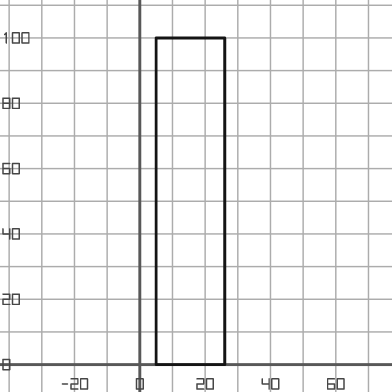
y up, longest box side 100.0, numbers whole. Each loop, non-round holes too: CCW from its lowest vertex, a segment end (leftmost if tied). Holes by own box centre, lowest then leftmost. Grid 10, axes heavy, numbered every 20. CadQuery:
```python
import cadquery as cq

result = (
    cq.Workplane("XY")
    .moveTo(5.0, 0.0)
    .lineTo(26.0, 0.0)
    .lineTo(26.0, 100.0)
    .lineTo(5.0, 100.0)
    .close()
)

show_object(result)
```